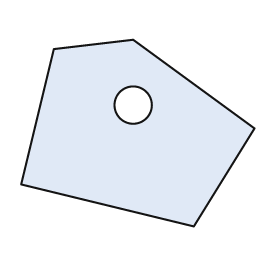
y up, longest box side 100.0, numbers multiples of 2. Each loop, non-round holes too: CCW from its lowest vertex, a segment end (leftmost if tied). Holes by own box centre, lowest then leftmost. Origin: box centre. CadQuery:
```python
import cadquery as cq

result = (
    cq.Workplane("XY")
    .moveTo(24.0, -40.0)
    .lineTo(50.0, 2.0)
    .lineTo(-2.0, 40.0)
    .lineTo(-36.0, 36.0)
    .lineTo(-50.0, -22.0)
    .close()
    .moveTo(-2.0, 12.0)
    .circle(8.0)
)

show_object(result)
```